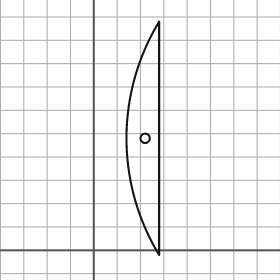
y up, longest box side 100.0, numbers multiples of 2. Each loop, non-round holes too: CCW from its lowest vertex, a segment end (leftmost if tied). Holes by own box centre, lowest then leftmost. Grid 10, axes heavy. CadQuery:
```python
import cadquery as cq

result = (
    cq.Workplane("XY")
    .moveTo(28.0, -2.0)
    .lineTo(28.0, 98.0)
    .threePointArc((14.0, 48.0), (28.0, -2.0))
    .close()
    .moveTo(22.0, 48.0)
    .circle(2.0)
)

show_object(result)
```